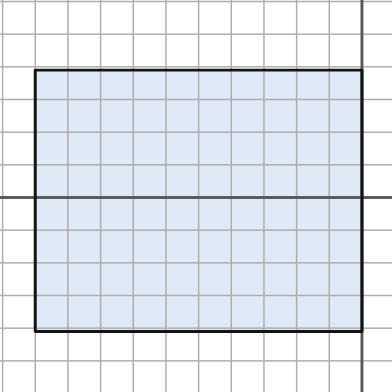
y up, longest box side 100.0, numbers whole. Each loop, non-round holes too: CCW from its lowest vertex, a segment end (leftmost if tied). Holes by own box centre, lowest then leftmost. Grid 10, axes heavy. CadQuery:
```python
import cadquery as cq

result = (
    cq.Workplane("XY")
    .moveTo(-100.0, -41.0)
    .lineTo(0.0, -41.0)
    .lineTo(0.0, 39.0)
    .lineTo(-100.0, 39.0)
    .close()
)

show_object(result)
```